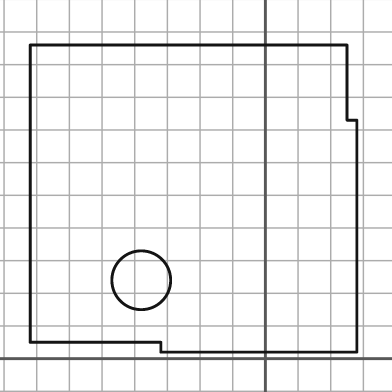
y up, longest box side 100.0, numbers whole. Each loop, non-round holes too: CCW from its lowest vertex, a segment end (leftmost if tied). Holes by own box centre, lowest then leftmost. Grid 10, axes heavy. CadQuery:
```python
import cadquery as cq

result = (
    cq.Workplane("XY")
    .moveTo(-32.0, 2.0)
    .lineTo(28.0, 2.0)
    .lineTo(28.0, 73.0)
    .lineTo(25.0, 73.0)
    .lineTo(25.0, 96.0)
    .lineTo(-72.0, 96.0)
    .lineTo(-72.0, 5.0)
    .lineTo(-32.0, 5.0)
    .close()
    .moveTo(-38.0, 24.0)
    .circle(9.0)
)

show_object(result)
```